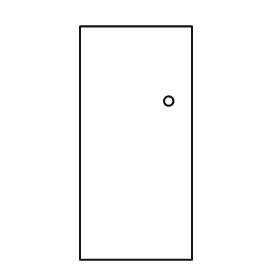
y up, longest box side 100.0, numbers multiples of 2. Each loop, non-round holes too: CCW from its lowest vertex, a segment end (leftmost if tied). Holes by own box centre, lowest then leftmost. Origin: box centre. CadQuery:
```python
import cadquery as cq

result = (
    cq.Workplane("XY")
    .moveTo(-24.0, -50.0)
    .lineTo(24.0, -50.0)
    .lineTo(24.0, 50.0)
    .lineTo(-24.0, 50.0)
    .close()
    .moveTo(14.0, 18.0)
    .circle(2.0)
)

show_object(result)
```